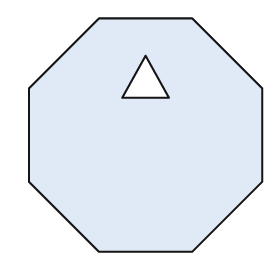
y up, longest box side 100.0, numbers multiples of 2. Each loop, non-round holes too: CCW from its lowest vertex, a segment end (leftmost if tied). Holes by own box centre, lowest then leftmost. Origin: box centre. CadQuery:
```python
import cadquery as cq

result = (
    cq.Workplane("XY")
    .moveTo(-20.0, -50.0)
    .lineTo(20.0, -50.0)
    .lineTo(50.0, -20.0)
    .lineTo(50.0, 20.0)
    .lineTo(20.0, 50.0)
    .lineTo(-20.0, 50.0)
    .lineTo(-50.0, 20.0)
    .lineTo(-50.0, -20.0)
    .close()
    .moveTo(-10.0, 16.0)
    .lineTo(10.0, 16.0)
    .lineTo(0.0, 34.0)
    .close()
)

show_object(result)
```